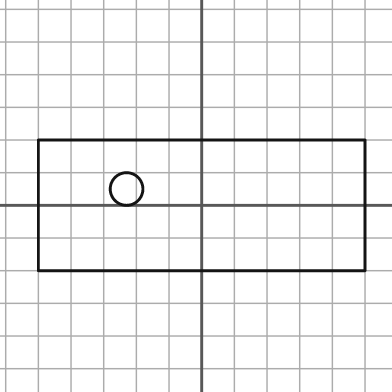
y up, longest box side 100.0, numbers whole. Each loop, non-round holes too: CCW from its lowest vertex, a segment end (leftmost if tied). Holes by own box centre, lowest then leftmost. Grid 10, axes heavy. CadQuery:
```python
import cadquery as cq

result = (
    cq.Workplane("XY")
    .moveTo(-50.0, -20.0)
    .lineTo(50.0, -20.0)
    .lineTo(50.0, 20.0)
    .lineTo(-50.0, 20.0)
    .close()
    .moveTo(-23.0, 5.0)
    .circle(5.0)
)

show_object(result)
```